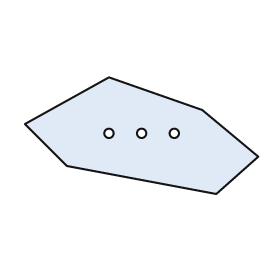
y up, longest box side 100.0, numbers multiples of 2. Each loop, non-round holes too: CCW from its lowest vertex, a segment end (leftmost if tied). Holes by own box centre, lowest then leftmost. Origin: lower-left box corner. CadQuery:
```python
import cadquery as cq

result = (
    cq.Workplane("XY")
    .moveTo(82.0, 0.0)
    .lineTo(100.0, 16.0)
    .lineTo(76.0, 36.0)
    .lineTo(36.0, 50.0)
    .lineTo(0.0, 30.0)
    .lineTo(18.0, 12.0)
    .close()
    .moveTo(36.0, 26.0)
    .circle(2.0)
    .moveTo(50.0, 26.0)
    .circle(2.0)
    .moveTo(64.0, 26.0)
    .circle(2.0)
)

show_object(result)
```